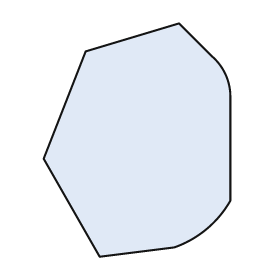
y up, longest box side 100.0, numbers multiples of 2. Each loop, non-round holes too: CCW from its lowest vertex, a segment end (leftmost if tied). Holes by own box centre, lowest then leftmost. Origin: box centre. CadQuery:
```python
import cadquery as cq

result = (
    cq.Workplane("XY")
    .moveTo(-16.0, -50.0)
    .lineTo(16.0, -46.0)
    .threePointArc((30.0, -38.0), (40.0, -26.0))
    .lineTo(40.0, 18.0)
    .threePointArc((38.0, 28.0), (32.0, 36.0))
    .lineTo(18.0, 50.0)
    .lineTo(-22.0, 38.0)
    .lineTo(-40.0, -8.0)
    .close()
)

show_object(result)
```